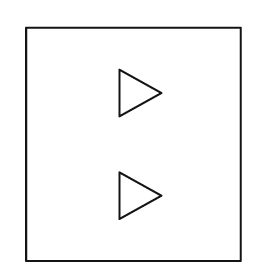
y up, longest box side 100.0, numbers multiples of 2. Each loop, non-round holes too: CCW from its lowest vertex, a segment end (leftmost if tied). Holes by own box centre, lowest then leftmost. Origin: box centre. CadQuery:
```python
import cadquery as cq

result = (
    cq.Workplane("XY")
    .moveTo(-46.0, -50.0)
    .lineTo(46.0, -50.0)
    .lineTo(46.0, 50.0)
    .lineTo(-46.0, 50.0)
    .close()
    .moveTo(-6.0, -32.0)
    .lineTo(12.0, -22.0)
    .lineTo(-6.0, -12.0)
    .close()
    .moveTo(-6.0, 12.0)
    .lineTo(12.0, 22.0)
    .lineTo(-6.0, 32.0)
    .close()
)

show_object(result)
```